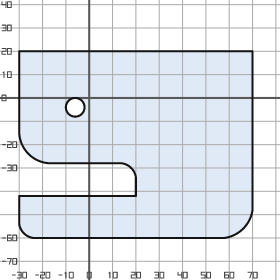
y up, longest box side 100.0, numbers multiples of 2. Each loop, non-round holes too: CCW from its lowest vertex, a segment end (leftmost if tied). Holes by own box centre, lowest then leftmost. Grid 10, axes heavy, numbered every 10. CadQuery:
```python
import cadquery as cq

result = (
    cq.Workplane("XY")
    .moveTo(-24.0, -60.0)
    .lineTo(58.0, -60.0)
    .threePointArc((66.0, -56.0), (70.0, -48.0))
    .lineTo(70.0, 20.0)
    .lineTo(-30.0, 20.0)
    .lineTo(-30.0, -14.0)
    .threePointArc((-26.0, -24.0), (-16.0, -28.0))
    .lineTo(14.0, -28.0)
    .threePointArc((18.0, -30.0), (20.0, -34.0))
    .lineTo(20.0, -42.0)
    .lineTo(-30.0, -42.0)
    .lineTo(-30.0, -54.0)
    .threePointArc((-28.0, -58.0), (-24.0, -60.0))
    .close()
    .moveTo(-6.0, -4.0)
    .circle(4.0)
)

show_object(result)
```